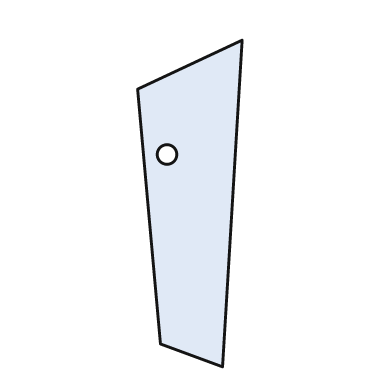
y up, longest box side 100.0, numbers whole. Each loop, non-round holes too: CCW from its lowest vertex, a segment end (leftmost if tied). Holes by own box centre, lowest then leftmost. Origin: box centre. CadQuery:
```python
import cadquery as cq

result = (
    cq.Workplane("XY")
    .moveTo(10.0, -50.0)
    .lineTo(16.0, 50.0)
    .lineTo(-16.0, 35.0)
    .lineTo(-9.0, -43.0)
    .close()
    .moveTo(-7.0, 15.0)
    .circle(3.0)
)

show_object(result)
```